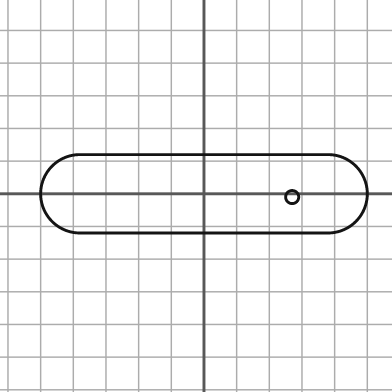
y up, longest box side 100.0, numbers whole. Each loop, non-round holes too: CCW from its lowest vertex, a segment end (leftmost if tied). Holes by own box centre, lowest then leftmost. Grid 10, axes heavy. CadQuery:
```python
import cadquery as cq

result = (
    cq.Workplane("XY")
    .moveTo(-38.0, -12.0)
    .lineTo(38.0, -12.0)
    .threePointArc((50.0, 0.0), (38.0, 12.0))
    .lineTo(-38.0, 12.0)
    .threePointArc((-50.0, 0.0), (-38.0, -12.0))
    .close()
    .moveTo(27.0, -1.0)
    .circle(2.0)
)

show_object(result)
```